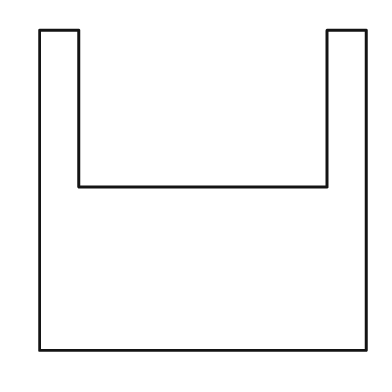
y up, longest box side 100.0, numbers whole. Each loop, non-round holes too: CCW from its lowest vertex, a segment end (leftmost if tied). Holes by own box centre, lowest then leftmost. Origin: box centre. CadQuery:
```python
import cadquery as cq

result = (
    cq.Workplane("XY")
    .moveTo(-50.0, -49.0)
    .lineTo(50.0, -49.0)
    .lineTo(50.0, 49.0)
    .lineTo(38.0, 49.0)
    .lineTo(38.0, 1.0)
    .lineTo(-38.0, 1.0)
    .lineTo(-38.0, 49.0)
    .lineTo(-50.0, 49.0)
    .close()
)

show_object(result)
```